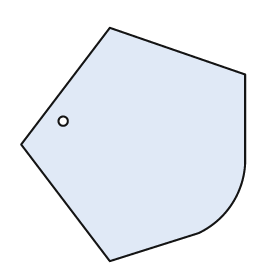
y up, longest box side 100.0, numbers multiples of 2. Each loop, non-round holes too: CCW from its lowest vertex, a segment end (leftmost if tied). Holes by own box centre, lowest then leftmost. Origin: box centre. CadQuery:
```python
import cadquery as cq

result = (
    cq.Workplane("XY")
    .moveTo(-10.0, -50.0)
    .lineTo(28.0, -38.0)
    .threePointArc((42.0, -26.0), (48.0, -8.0))
    .lineTo(48.0, 30.0)
    .lineTo(-10.0, 50.0)
    .lineTo(-48.0, 0.0)
    .close()
    .moveTo(-30.0, 10.0)
    .circle(2.0)
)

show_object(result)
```